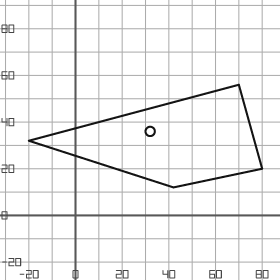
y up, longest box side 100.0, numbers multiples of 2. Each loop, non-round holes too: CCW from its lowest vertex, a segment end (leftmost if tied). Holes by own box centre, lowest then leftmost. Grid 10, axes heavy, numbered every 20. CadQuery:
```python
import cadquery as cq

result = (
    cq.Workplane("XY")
    .moveTo(42.0, 12.0)
    .lineTo(80.0, 20.0)
    .lineTo(70.0, 56.0)
    .lineTo(-20.0, 32.0)
    .close()
    .moveTo(32.0, 36.0)
    .circle(2.0)
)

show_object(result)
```